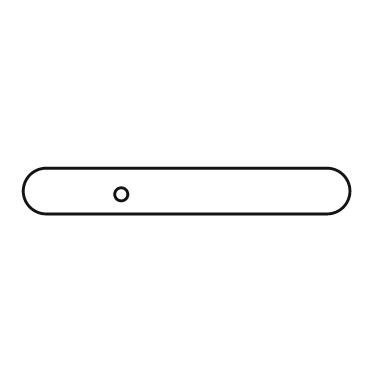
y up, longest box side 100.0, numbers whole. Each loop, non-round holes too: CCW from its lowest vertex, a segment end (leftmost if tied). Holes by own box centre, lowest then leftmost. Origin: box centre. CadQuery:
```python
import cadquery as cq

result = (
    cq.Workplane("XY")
    .moveTo(-43.0, -7.0)
    .lineTo(43.0, -7.0)
    .threePointArc((50.0, 0.0), (43.0, 7.0))
    .lineTo(-43.0, 7.0)
    .threePointArc((-50.0, 0.0), (-43.0, -7.0))
    .close()
    .moveTo(-20.0, -1.0)
    .circle(2.0)
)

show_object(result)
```